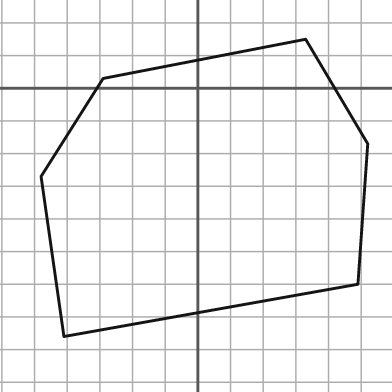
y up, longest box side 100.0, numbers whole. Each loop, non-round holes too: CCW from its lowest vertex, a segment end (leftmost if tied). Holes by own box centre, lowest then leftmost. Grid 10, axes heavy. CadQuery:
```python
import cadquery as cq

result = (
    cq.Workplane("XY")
    .moveTo(-41.0, -76.0)
    .lineTo(49.0, -60.0)
    .lineTo(52.0, -17.0)
    .lineTo(33.0, 15.0)
    .lineTo(-29.0, 3.0)
    .lineTo(-48.0, -27.0)
    .close()
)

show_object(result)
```